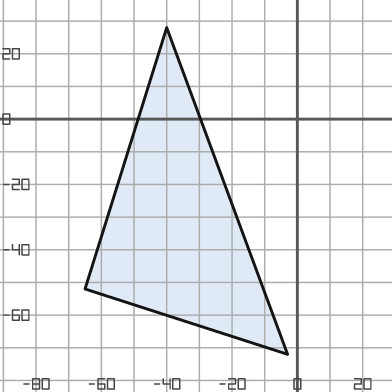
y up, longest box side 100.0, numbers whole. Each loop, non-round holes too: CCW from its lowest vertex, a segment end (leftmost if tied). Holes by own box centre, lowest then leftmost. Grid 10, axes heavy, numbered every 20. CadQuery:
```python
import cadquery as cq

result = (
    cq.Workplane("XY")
    .moveTo(-3.0, -72.0)
    .lineTo(-40.0, 28.0)
    .lineTo(-65.0, -52.0)
    .close()
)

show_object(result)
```